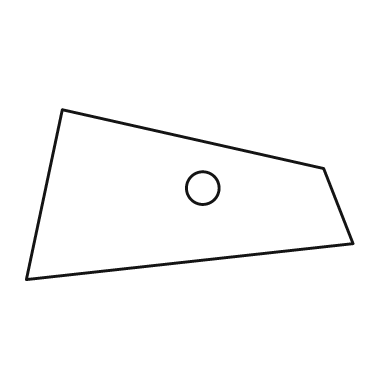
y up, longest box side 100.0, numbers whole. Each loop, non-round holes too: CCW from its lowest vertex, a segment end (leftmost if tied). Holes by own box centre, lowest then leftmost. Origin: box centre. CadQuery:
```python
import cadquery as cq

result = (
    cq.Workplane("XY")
    .moveTo(-50.0, -26.0)
    .lineTo(50.0, -15.0)
    .lineTo(41.0, 8.0)
    .lineTo(-39.0, 26.0)
    .close()
    .moveTo(4.0, 2.0)
    .circle(5.0)
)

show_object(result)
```